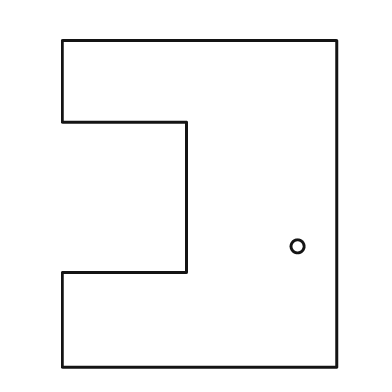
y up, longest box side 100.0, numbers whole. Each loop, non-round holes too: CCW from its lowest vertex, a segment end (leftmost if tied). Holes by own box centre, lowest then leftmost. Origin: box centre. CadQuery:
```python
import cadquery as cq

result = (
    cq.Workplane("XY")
    .moveTo(-42.0, -50.0)
    .lineTo(42.0, -50.0)
    .lineTo(42.0, 50.0)
    .lineTo(-42.0, 50.0)
    .lineTo(-42.0, 25.0)
    .lineTo(-4.0, 25.0)
    .lineTo(-4.0, -21.0)
    .lineTo(-42.0, -21.0)
    .close()
    .moveTo(30.0, -13.0)
    .circle(2.0)
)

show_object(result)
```